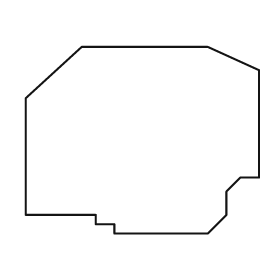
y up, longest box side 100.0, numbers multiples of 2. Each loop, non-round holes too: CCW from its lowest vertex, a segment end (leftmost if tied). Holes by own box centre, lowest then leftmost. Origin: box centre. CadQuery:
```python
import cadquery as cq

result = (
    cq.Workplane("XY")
    .moveTo(-12.0, -40.0)
    .lineTo(28.0, -40.0)
    .lineTo(36.0, -32.0)
    .lineTo(36.0, -22.0)
    .lineTo(42.0, -16.0)
    .lineTo(50.0, -16.0)
    .lineTo(50.0, 30.0)
    .lineTo(28.0, 40.0)
    .lineTo(-26.0, 40.0)
    .lineTo(-50.0, 18.0)
    .lineTo(-50.0, -32.0)
    .lineTo(-20.0, -32.0)
    .lineTo(-20.0, -36.0)
    .lineTo(-12.0, -36.0)
    .close()
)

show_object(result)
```